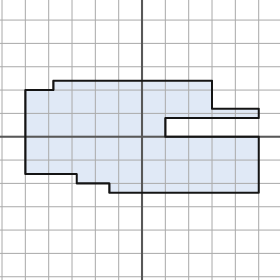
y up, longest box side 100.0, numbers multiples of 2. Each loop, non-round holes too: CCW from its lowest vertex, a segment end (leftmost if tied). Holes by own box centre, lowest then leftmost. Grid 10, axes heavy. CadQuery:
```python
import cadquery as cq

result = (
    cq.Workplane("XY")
    .moveTo(-14.0, -24.0)
    .lineTo(50.0, -24.0)
    .lineTo(50.0, 0.0)
    .lineTo(10.0, 0.0)
    .lineTo(10.0, 8.0)
    .lineTo(50.0, 8.0)
    .lineTo(50.0, 12.0)
    .lineTo(30.0, 12.0)
    .lineTo(30.0, 24.0)
    .lineTo(-38.0, 24.0)
    .lineTo(-38.0, 20.0)
    .lineTo(-50.0, 20.0)
    .lineTo(-50.0, -16.0)
    .lineTo(-28.0, -16.0)
    .lineTo(-28.0, -20.0)
    .lineTo(-14.0, -20.0)
    .close()
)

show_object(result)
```